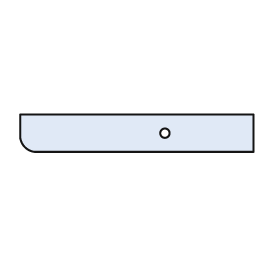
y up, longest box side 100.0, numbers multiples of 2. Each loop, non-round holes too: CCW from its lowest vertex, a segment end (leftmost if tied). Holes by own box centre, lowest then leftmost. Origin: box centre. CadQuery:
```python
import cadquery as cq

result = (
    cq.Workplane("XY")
    .moveTo(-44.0, -8.0)
    .lineTo(50.0, -8.0)
    .lineTo(50.0, 8.0)
    .lineTo(-50.0, 8.0)
    .lineTo(-50.0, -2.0)
    .threePointArc((-48.0, -6.0), (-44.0, -8.0))
    .close()
    .moveTo(12.0, 0.0)
    .circle(2.0)
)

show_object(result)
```